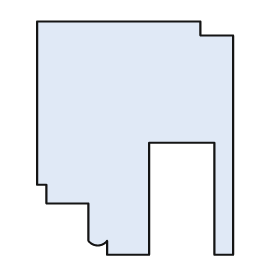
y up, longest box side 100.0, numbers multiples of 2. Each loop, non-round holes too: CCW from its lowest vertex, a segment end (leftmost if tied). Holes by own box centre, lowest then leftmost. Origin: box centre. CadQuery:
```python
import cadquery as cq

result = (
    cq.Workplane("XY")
    .moveTo(-12.0, -50.0)
    .lineTo(6.0, -50.0)
    .lineTo(6.0, -2.0)
    .lineTo(34.0, -2.0)
    .lineTo(34.0, -50.0)
    .lineTo(42.0, -50.0)
    .lineTo(42.0, 44.0)
    .lineTo(28.0, 44.0)
    .lineTo(28.0, 50.0)
    .lineTo(-42.0, 50.0)
    .lineTo(-42.0, -20.0)
    .lineTo(-38.0, -20.0)
    .lineTo(-38.0, -28.0)
    .lineTo(-20.0, -28.0)
    .lineTo(-20.0, -44.0)
    .threePointArc((-16.0, -46.0), (-12.0, -44.0))
    .close()
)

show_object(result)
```